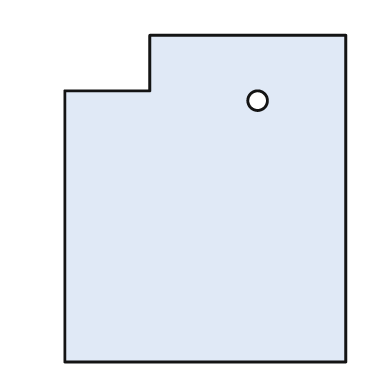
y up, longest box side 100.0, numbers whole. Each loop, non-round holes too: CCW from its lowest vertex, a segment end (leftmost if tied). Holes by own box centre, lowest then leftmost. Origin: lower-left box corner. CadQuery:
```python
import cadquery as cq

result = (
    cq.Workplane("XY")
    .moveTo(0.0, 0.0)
    .lineTo(86.0, 0.0)
    .lineTo(86.0, 100.0)
    .lineTo(26.0, 100.0)
    .lineTo(26.0, 83.0)
    .lineTo(0.0, 83.0)
    .close()
    .moveTo(59.0, 80.0)
    .circle(3.0)
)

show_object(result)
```